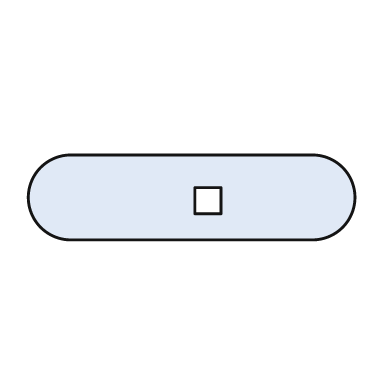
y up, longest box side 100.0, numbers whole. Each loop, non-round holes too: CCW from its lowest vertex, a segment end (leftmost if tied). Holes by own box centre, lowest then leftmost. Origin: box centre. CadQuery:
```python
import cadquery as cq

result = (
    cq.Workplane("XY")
    .moveTo(-37.0, -13.0)
    .lineTo(37.0, -13.0)
    .threePointArc((50.0, 0.0), (37.0, 13.0))
    .lineTo(-37.0, 13.0)
    .threePointArc((-50.0, 0.0), (-37.0, -13.0))
    .close()
    .moveTo(1.0, -5.0)
    .lineTo(9.0, -5.0)
    .lineTo(9.0, 3.0)
    .lineTo(1.0, 3.0)
    .close()
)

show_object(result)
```